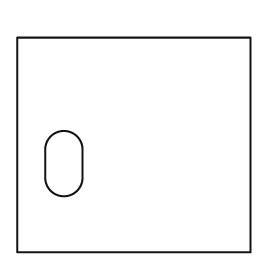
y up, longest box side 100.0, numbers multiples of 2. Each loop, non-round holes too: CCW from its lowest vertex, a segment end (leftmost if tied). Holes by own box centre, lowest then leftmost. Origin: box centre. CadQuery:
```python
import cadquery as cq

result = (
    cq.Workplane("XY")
    .moveTo(-50.0, -46.0)
    .lineTo(50.0, -46.0)
    .lineTo(50.0, 46.0)
    .lineTo(-50.0, 46.0)
    .close()
    .moveTo(-38.0, -14.0)
    .threePointArc((-30.0, -22.0), (-22.0, -14.0))
    .lineTo(-22.0, -2.0)
    .threePointArc((-30.0, 6.0), (-38.0, -2.0))
    .close()
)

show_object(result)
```